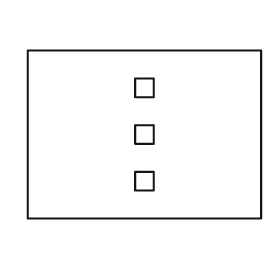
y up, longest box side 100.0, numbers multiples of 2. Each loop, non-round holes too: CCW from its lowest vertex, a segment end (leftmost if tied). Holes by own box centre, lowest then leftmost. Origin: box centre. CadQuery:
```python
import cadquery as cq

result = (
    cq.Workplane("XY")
    .moveTo(-50.0, -36.0)
    .lineTo(50.0, -36.0)
    .lineTo(50.0, 36.0)
    .lineTo(-50.0, 36.0)
    .close()
    .moveTo(-4.0, -24.0)
    .lineTo(4.0, -24.0)
    .lineTo(4.0, -16.0)
    .lineTo(-4.0, -16.0)
    .close()
    .moveTo(-4.0, -4.0)
    .lineTo(4.0, -4.0)
    .lineTo(4.0, 4.0)
    .lineTo(-4.0, 4.0)
    .close()
    .moveTo(-4.0, 16.0)
    .lineTo(4.0, 16.0)
    .lineTo(4.0, 24.0)
    .lineTo(-4.0, 24.0)
    .close()
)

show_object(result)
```